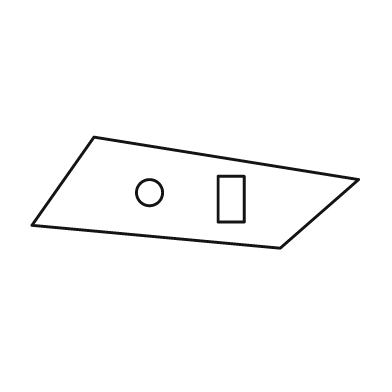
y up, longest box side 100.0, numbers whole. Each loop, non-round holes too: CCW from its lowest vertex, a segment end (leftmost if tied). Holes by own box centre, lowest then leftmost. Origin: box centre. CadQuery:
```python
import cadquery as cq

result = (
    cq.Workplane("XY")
    .moveTo(26.0, -17.0)
    .lineTo(50.0, 4.0)
    .lineTo(-31.0, 17.0)
    .lineTo(-50.0, -10.0)
    .close()
    .moveTo(7.0, -9.0)
    .lineTo(15.0, -9.0)
    .lineTo(15.0, 5.0)
    .lineTo(7.0, 5.0)
    .close()
    .moveTo(-14.0, 0.0)
    .circle(4.0)
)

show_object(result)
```